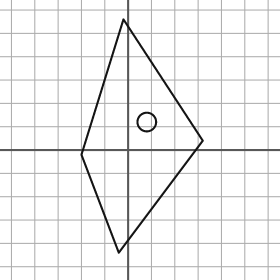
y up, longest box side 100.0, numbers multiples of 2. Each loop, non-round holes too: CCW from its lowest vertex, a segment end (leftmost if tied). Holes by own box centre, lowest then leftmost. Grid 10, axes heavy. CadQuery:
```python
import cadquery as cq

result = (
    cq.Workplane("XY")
    .moveTo(-4.0, -44.0)
    .lineTo(32.0, 4.0)
    .lineTo(-2.0, 56.0)
    .lineTo(-20.0, -2.0)
    .close()
    .moveTo(8.0, 12.0)
    .circle(4.0)
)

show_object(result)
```